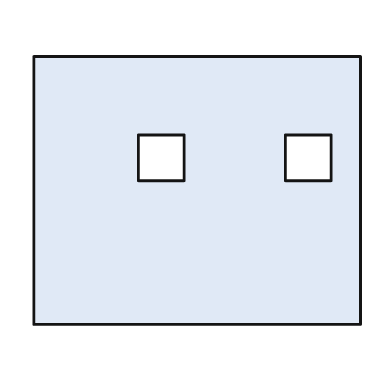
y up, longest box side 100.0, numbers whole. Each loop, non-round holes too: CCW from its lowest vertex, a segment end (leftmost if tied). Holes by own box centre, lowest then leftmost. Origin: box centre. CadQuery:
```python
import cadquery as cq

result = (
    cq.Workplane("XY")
    .moveTo(-50.0, -41.0)
    .lineTo(50.0, -41.0)
    .lineTo(50.0, 41.0)
    .lineTo(-50.0, 41.0)
    .close()
    .moveTo(-18.0, 3.0)
    .lineTo(-4.0, 3.0)
    .lineTo(-4.0, 17.0)
    .lineTo(-18.0, 17.0)
    .close()
    .moveTo(27.0, 3.0)
    .lineTo(41.0, 3.0)
    .lineTo(41.0, 17.0)
    .lineTo(27.0, 17.0)
    .close()
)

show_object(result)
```